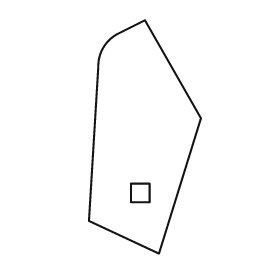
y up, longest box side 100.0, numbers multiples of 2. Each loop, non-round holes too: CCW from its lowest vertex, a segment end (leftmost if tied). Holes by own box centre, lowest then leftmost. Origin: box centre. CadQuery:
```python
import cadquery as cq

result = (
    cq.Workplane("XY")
    .moveTo(6.0, -50.0)
    .lineTo(24.0, 8.0)
    .lineTo(0.0, 50.0)
    .lineTo(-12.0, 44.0)
    .threePointArc((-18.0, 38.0), (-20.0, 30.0))
    .lineTo(-24.0, -36.0)
    .close()
    .moveTo(-6.0, -28.0)
    .lineTo(2.0, -28.0)
    .lineTo(2.0, -20.0)
    .lineTo(-6.0, -20.0)
    .close()
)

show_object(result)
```